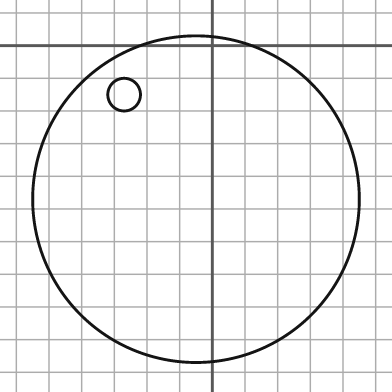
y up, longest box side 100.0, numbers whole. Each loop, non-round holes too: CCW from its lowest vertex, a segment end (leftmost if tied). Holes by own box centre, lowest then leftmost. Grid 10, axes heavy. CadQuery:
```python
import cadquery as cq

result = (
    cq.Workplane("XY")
    .moveTo(-5.0, -47.0)
    .circle(50.0)
    .moveTo(-27.0, -15.0)
    .circle(5.0)
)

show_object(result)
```